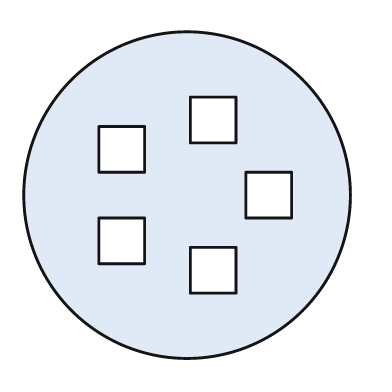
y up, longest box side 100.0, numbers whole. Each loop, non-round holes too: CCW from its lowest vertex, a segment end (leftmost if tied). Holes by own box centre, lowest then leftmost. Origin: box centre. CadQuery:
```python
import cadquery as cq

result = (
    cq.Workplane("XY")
    .moveTo(0.0, 0.0)
    .circle(50.0)
    .moveTo(1.0, -30.0)
    .lineTo(15.0, -30.0)
    .lineTo(15.0, -16.0)
    .lineTo(1.0, -16.0)
    .close()
    .moveTo(-27.0, -21.0)
    .lineTo(-13.0, -21.0)
    .lineTo(-13.0, -7.0)
    .lineTo(-27.0, -7.0)
    .close()
    .moveTo(18.0, -7.0)
    .lineTo(32.0, -7.0)
    .lineTo(32.0, 7.0)
    .lineTo(18.0, 7.0)
    .close()
    .moveTo(-27.0, 7.0)
    .lineTo(-13.0, 7.0)
    .lineTo(-13.0, 21.0)
    .lineTo(-27.0, 21.0)
    .close()
    .moveTo(1.0, 16.0)
    .lineTo(15.0, 16.0)
    .lineTo(15.0, 30.0)
    .lineTo(1.0, 30.0)
    .close()
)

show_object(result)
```